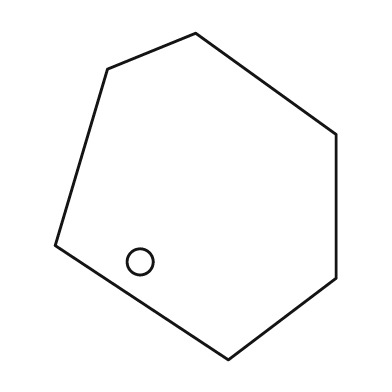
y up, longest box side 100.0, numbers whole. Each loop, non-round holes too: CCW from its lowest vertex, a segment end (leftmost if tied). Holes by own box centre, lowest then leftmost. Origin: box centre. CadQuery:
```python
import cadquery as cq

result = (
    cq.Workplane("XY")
    .moveTo(10.0, -50.0)
    .lineTo(43.0, -25.0)
    .lineTo(43.0, 19.0)
    .lineTo(0.0, 50.0)
    .lineTo(-27.0, 39.0)
    .lineTo(-43.0, -15.0)
    .close()
    .moveTo(-17.0, -20.0)
    .circle(4.0)
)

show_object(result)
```